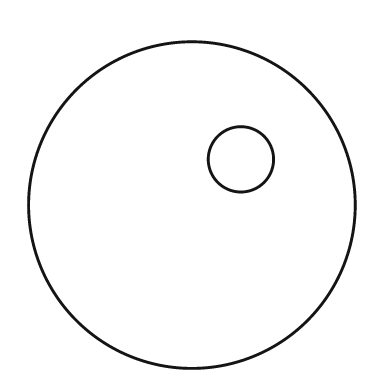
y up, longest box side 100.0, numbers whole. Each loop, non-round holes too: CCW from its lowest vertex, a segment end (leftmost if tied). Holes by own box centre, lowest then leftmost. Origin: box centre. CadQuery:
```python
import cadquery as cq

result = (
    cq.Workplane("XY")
    .moveTo(0.0, 0.0)
    .circle(50.0)
    .moveTo(15.0, 14.0)
    .circle(10.0)
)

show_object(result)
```